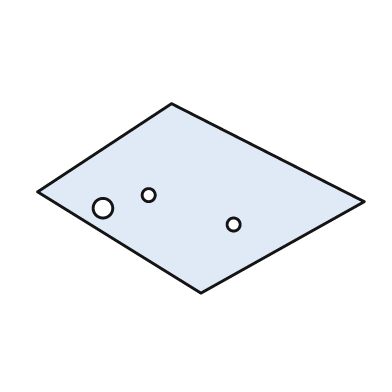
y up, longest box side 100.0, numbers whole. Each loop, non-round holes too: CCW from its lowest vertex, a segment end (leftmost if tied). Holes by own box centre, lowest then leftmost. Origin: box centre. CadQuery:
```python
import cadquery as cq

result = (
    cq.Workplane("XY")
    .moveTo(0.0, -29.0)
    .lineTo(50.0, -1.0)
    .lineTo(-9.0, 29.0)
    .lineTo(-50.0, 2.0)
    .close()
    .moveTo(10.0, -8.0)
    .circle(2.0)
    .moveTo(-30.0, -3.0)
    .circle(3.0)
    .moveTo(-16.0, 1.0)
    .circle(2.0)
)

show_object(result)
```